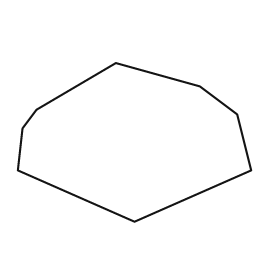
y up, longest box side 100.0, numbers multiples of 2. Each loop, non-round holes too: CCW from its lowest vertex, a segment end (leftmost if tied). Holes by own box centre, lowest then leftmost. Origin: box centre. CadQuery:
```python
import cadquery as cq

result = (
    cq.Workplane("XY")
    .moveTo(0.0, -34.0)
    .lineTo(50.0, -12.0)
    .lineTo(44.0, 12.0)
    .lineTo(28.0, 24.0)
    .lineTo(-8.0, 34.0)
    .lineTo(-42.0, 14.0)
    .lineTo(-48.0, 6.0)
    .lineTo(-50.0, -12.0)
    .close()
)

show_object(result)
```